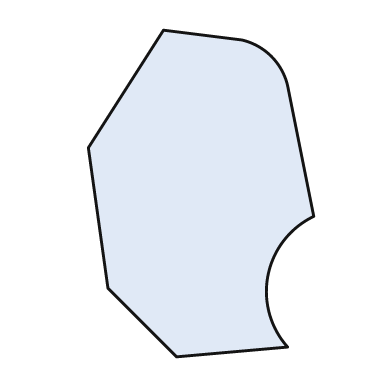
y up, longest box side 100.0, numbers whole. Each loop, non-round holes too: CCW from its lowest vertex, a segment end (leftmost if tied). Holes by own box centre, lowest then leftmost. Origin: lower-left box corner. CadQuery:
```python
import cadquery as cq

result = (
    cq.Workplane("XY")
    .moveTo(27.0, 0.0)
    .lineTo(61.0, 3.0)
    .threePointArc((55.0, 25.0), (69.0, 43.0))
    .lineTo(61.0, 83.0)
    .threePointArc((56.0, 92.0), (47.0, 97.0))
    .lineTo(23.0, 100.0)
    .lineTo(0.0, 64.0)
    .lineTo(6.0, 21.0)
    .close()
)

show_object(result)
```